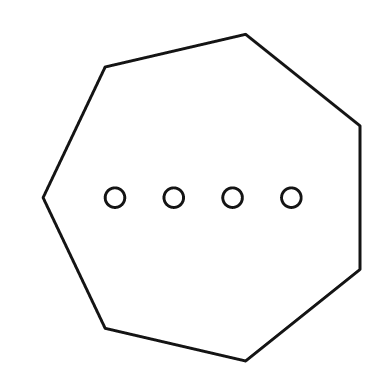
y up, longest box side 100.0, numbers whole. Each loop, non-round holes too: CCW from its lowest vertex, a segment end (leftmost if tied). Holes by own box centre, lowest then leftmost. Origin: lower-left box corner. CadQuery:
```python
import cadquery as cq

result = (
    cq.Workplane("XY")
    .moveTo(62.0, 0.0)
    .lineTo(97.0, 28.0)
    .lineTo(97.0, 72.0)
    .lineTo(62.0, 100.0)
    .lineTo(19.0, 90.0)
    .lineTo(0.0, 50.0)
    .lineTo(19.0, 10.0)
    .close()
    .moveTo(22.0, 50.0)
    .circle(3.0)
    .moveTo(40.0, 50.0)
    .circle(3.0)
    .moveTo(58.0, 50.0)
    .circle(3.0)
    .moveTo(76.0, 50.0)
    .circle(3.0)
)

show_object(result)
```